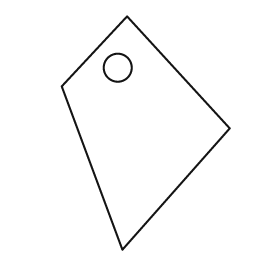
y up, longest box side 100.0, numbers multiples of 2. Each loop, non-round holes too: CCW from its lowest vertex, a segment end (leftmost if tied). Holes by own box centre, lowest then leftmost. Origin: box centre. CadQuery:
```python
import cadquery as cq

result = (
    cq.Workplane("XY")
    .moveTo(-10.0, -50.0)
    .lineTo(36.0, 2.0)
    .lineTo(-8.0, 50.0)
    .lineTo(-36.0, 20.0)
    .close()
    .moveTo(-12.0, 28.0)
    .circle(6.0)
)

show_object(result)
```